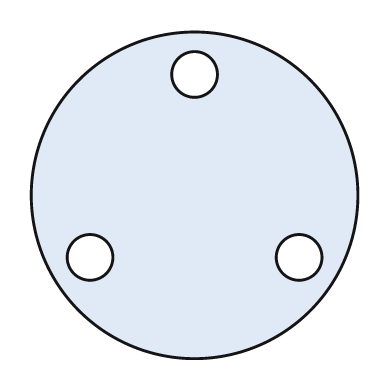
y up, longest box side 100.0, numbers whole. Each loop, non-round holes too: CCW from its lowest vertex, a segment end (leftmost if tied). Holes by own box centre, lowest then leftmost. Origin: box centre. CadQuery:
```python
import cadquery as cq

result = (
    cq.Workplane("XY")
    .moveTo(0.0, 0.0)
    .circle(50.0)
    .moveTo(-32.0, -19.0)
    .circle(7.0)
    .moveTo(32.0, -19.0)
    .circle(7.0)
    .moveTo(0.0, 37.0)
    .circle(7.0)
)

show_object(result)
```